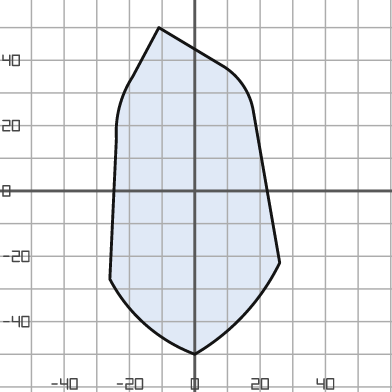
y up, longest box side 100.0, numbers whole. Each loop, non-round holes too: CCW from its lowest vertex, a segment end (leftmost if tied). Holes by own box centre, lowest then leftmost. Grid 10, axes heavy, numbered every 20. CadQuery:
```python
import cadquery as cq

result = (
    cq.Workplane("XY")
    .moveTo(0.0, -50.0)
    .threePointArc((15.0, -38.0), (26.0, -22.0))
    .lineTo(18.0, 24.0)
    .threePointArc((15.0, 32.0), (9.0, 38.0))
    .lineTo(-11.0, 50.0)
    .lineTo(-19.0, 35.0)
    .threePointArc((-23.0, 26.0), (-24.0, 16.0))
    .lineTo(-26.0, -27.0)
    .threePointArc((-15.0, -41.0), (0.0, -50.0))
    .close()
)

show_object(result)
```